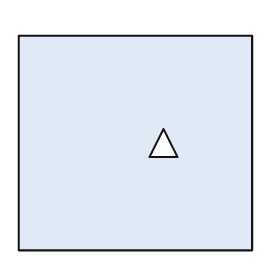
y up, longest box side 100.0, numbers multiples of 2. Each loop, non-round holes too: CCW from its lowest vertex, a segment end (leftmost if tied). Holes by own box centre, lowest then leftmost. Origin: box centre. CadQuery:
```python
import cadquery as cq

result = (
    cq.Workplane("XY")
    .moveTo(-50.0, -46.0)
    .lineTo(50.0, -46.0)
    .lineTo(50.0, 46.0)
    .lineTo(-50.0, 46.0)
    .close()
    .moveTo(6.0, -6.0)
    .lineTo(18.0, -6.0)
    .lineTo(12.0, 6.0)
    .close()
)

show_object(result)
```